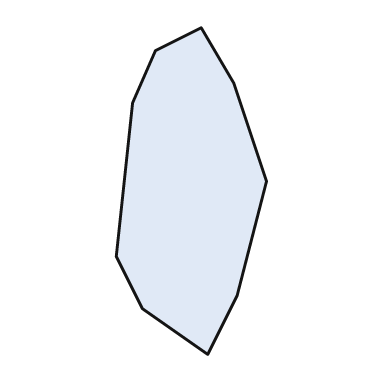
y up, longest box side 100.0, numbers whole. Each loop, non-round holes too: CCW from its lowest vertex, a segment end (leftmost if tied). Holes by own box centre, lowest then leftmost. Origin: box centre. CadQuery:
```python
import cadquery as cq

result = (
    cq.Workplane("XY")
    .moveTo(5.0, -50.0)
    .lineTo(14.0, -32.0)
    .lineTo(23.0, 3.0)
    .lineTo(13.0, 33.0)
    .lineTo(3.0, 50.0)
    .lineTo(-11.0, 43.0)
    .lineTo(-18.0, 27.0)
    .lineTo(-23.0, -20.0)
    .lineTo(-15.0, -36.0)
    .close()
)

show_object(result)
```